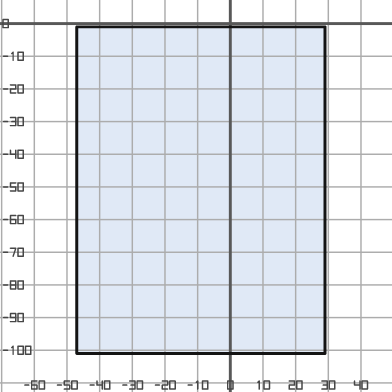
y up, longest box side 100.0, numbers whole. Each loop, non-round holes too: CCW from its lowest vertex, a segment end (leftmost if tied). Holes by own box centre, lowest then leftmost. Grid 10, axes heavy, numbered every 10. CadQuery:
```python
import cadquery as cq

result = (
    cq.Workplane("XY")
    .moveTo(-47.0, -101.0)
    .lineTo(29.0, -101.0)
    .lineTo(29.0, -1.0)
    .lineTo(-47.0, -1.0)
    .close()
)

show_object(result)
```